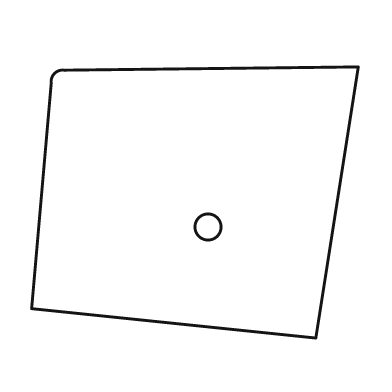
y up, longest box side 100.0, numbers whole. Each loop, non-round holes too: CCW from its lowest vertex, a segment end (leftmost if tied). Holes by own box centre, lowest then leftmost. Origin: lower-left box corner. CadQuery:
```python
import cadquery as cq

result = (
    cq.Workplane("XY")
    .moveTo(87.0, 0.0)
    .lineTo(100.0, 83.0)
    .lineTo(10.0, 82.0)
    .threePointArc((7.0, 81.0), (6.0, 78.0))
    .lineTo(0.0, 9.0)
    .close()
    .moveTo(54.0, 34.0)
    .circle(4.0)
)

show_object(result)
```